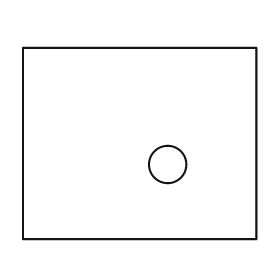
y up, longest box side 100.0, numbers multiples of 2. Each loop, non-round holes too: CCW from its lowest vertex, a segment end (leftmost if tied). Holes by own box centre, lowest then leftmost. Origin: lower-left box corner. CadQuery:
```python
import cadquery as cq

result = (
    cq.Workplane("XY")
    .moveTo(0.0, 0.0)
    .lineTo(100.0, 0.0)
    .lineTo(100.0, 82.0)
    .lineTo(0.0, 82.0)
    .close()
    .moveTo(62.0, 32.0)
    .circle(8.0)
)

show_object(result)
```